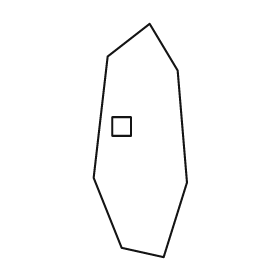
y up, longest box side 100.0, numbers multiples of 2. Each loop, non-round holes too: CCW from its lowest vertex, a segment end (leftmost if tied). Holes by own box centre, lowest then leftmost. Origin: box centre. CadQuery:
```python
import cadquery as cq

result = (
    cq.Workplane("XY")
    .moveTo(10.0, -50.0)
    .lineTo(20.0, -18.0)
    .lineTo(16.0, 30.0)
    .lineTo(4.0, 50.0)
    .lineTo(-14.0, 36.0)
    .lineTo(-20.0, -16.0)
    .lineTo(-8.0, -46.0)
    .close()
    .moveTo(-12.0, 2.0)
    .lineTo(-4.0, 2.0)
    .lineTo(-4.0, 10.0)
    .lineTo(-12.0, 10.0)
    .close()
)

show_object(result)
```